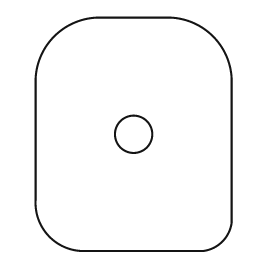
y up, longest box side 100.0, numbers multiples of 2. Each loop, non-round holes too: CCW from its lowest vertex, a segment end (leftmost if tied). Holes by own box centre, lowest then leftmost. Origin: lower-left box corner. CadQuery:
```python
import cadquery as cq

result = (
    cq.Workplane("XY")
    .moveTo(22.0, 0.0)
    .lineTo(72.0, 0.0)
    .threePointArc((80.0, 4.0), (84.0, 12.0))
    .lineTo(84.0, 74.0)
    .threePointArc((76.0, 92.0), (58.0, 100.0))
    .lineTo(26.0, 100.0)
    .threePointArc((8.0, 92.0), (0.0, 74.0))
    .lineTo(0.0, 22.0)
    .threePointArc((6.0, 6.0), (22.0, 0.0))
    .close()
    .moveTo(42.0, 50.0)
    .circle(8.0)
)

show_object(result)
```